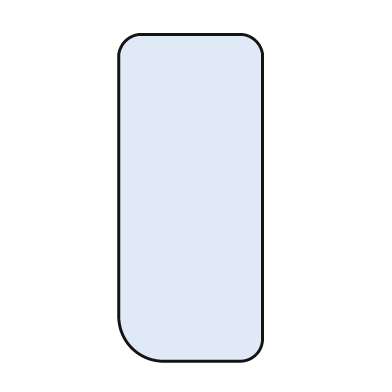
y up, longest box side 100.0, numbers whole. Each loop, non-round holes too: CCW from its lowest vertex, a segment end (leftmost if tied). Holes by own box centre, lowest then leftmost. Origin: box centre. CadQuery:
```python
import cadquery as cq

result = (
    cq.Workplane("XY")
    .moveTo(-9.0, -50.0)
    .lineTo(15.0, -50.0)
    .threePointArc((20.0, -48.0), (22.0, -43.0))
    .lineTo(22.0, 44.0)
    .threePointArc((20.0, 48.0), (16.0, 50.0))
    .lineTo(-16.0, 50.0)
    .threePointArc((-20.0, 48.0), (-22.0, 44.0))
    .lineTo(-22.0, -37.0)
    .threePointArc((-18.0, -46.0), (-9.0, -50.0))
    .close()
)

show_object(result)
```